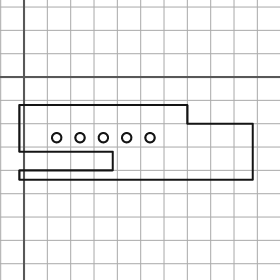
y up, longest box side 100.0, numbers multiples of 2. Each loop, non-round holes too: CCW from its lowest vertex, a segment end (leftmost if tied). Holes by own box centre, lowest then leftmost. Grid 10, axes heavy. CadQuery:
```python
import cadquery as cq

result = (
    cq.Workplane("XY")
    .moveTo(-2.0, -44.0)
    .lineTo(98.0, -44.0)
    .lineTo(98.0, -20.0)
    .lineTo(70.0, -20.0)
    .lineTo(70.0, -12.0)
    .lineTo(-2.0, -12.0)
    .lineTo(-2.0, -32.0)
    .lineTo(38.0, -32.0)
    .lineTo(38.0, -40.0)
    .lineTo(-2.0, -40.0)
    .close()
    .moveTo(14.0, -26.0)
    .circle(2.0)
    .moveTo(24.0, -26.0)
    .circle(2.0)
    .moveTo(34.0, -26.0)
    .circle(2.0)
    .moveTo(44.0, -26.0)
    .circle(2.0)
    .moveTo(54.0, -26.0)
    .circle(2.0)
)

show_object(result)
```